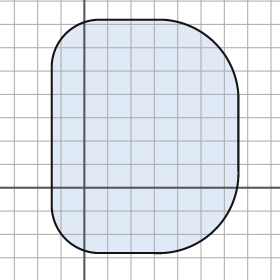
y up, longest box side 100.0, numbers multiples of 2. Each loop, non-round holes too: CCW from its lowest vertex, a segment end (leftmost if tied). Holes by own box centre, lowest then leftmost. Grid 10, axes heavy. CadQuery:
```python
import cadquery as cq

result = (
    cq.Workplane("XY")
    .moveTo(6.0, -28.0)
    .lineTo(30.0, -28.0)
    .threePointArc((56.0, -18.0), (66.0, 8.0))
    .lineTo(66.0, 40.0)
    .threePointArc((56.0, 62.0), (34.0, 72.0))
    .lineTo(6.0, 72.0)
    .threePointArc((-8.0, 66.0), (-14.0, 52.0))
    .lineTo(-14.0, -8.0)
    .threePointArc((-8.0, -22.0), (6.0, -28.0))
    .close()
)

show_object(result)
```